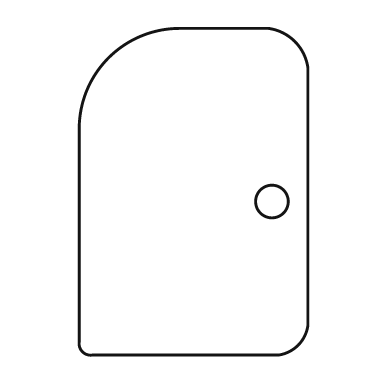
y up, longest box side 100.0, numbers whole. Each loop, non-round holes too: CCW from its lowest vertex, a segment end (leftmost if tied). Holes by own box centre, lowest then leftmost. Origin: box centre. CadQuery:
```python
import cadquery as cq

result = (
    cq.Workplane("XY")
    .moveTo(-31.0, -50.0)
    .lineTo(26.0, -50.0)
    .threePointArc((32.0, -47.0), (35.0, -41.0))
    .lineTo(35.0, 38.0)
    .threePointArc((31.0, 46.0), (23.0, 50.0))
    .lineTo(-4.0, 50.0)
    .threePointArc((-26.0, 41.0), (-35.0, 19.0))
    .lineTo(-35.0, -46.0)
    .threePointArc((-34.0, -49.0), (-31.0, -50.0))
    .close()
    .moveTo(24.0, -3.0)
    .circle(5.0)
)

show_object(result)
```